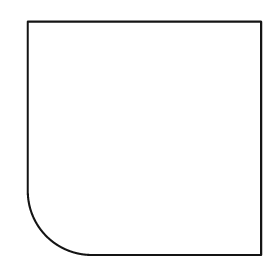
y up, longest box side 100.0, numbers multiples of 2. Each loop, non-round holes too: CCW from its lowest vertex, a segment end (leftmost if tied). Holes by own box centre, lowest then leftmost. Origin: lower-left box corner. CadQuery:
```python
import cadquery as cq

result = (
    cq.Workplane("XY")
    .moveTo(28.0, 0.0)
    .lineTo(100.0, 0.0)
    .lineTo(100.0, 100.0)
    .lineTo(0.0, 100.0)
    .lineTo(0.0, 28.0)
    .threePointArc((8.0, 8.0), (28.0, 0.0))
    .close()
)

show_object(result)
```